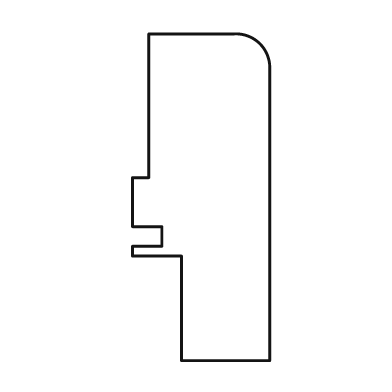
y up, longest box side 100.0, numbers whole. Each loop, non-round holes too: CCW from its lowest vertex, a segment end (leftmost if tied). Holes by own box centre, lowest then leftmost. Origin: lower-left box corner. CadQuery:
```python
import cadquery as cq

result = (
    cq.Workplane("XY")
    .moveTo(15.0, 0.0)
    .lineTo(42.0, 0.0)
    .lineTo(42.0, 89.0)
    .threePointArc((39.0, 97.0), (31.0, 100.0))
    .lineTo(5.0, 100.0)
    .lineTo(5.0, 56.0)
    .lineTo(0.0, 56.0)
    .lineTo(0.0, 41.0)
    .lineTo(9.0, 41.0)
    .lineTo(9.0, 35.0)
    .lineTo(0.0, 35.0)
    .lineTo(0.0, 32.0)
    .lineTo(15.0, 32.0)
    .close()
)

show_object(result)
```